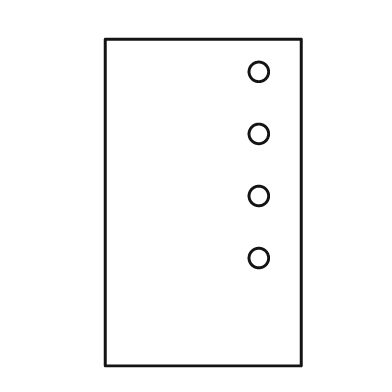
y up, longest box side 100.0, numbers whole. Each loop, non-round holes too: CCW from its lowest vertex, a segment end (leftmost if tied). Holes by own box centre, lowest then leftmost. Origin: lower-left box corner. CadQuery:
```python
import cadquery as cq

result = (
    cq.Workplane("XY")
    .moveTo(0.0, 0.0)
    .lineTo(60.0, 0.0)
    .lineTo(60.0, 100.0)
    .lineTo(0.0, 100.0)
    .close()
    .moveTo(47.0, 33.0)
    .circle(3.0)
    .moveTo(47.0, 52.0)
    .circle(3.0)
    .moveTo(47.0, 71.0)
    .circle(3.0)
    .moveTo(47.0, 90.0)
    .circle(3.0)
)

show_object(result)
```